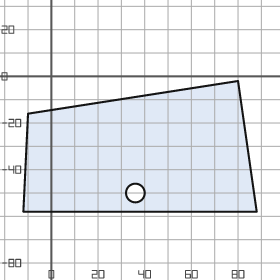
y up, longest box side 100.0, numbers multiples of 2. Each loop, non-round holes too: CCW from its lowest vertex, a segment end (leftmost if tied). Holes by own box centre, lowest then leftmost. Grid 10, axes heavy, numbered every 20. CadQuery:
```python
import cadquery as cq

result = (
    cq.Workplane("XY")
    .moveTo(-12.0, -58.0)
    .lineTo(88.0, -58.0)
    .lineTo(80.0, -2.0)
    .lineTo(-10.0, -16.0)
    .close()
    .moveTo(36.0, -50.0)
    .circle(4.0)
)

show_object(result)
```